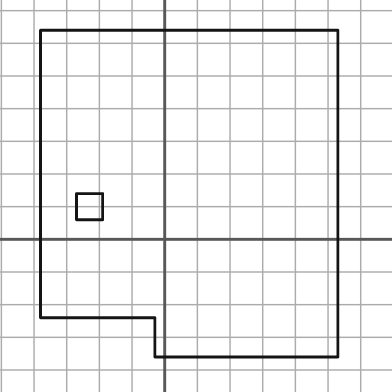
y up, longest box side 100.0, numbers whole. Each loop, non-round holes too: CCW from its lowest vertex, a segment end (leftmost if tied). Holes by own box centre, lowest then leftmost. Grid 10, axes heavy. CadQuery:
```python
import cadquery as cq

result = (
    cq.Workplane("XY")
    .moveTo(-3.0, -36.0)
    .lineTo(53.0, -36.0)
    .lineTo(53.0, 64.0)
    .lineTo(-38.0, 64.0)
    .lineTo(-38.0, -24.0)
    .lineTo(-3.0, -24.0)
    .close()
    .moveTo(-27.0, 6.0)
    .lineTo(-19.0, 6.0)
    .lineTo(-19.0, 14.0)
    .lineTo(-27.0, 14.0)
    .close()
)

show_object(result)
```